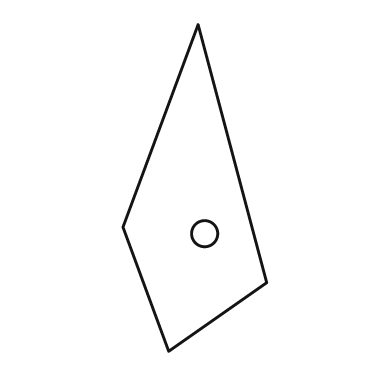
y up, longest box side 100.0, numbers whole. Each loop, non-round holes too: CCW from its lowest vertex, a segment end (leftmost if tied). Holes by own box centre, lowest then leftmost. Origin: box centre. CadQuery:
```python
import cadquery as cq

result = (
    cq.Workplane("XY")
    .moveTo(-8.0, -50.0)
    .lineTo(22.0, -29.0)
    .lineTo(1.0, 50.0)
    .lineTo(-22.0, -12.0)
    .close()
    .moveTo(3.0, -14.0)
    .circle(4.0)
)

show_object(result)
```